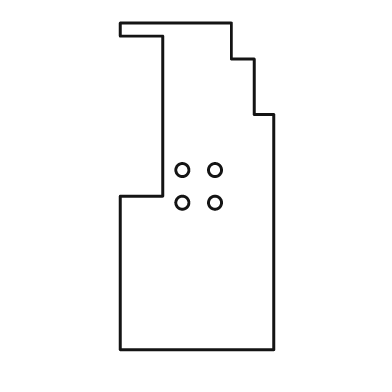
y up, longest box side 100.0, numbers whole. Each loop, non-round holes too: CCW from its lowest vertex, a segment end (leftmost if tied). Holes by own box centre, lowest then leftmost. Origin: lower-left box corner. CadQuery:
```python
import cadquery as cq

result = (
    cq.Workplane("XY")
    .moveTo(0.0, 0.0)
    .lineTo(47.0, 0.0)
    .lineTo(47.0, 72.0)
    .lineTo(41.0, 72.0)
    .lineTo(41.0, 89.0)
    .lineTo(34.0, 89.0)
    .lineTo(34.0, 100.0)
    .lineTo(0.0, 100.0)
    .lineTo(0.0, 96.0)
    .lineTo(13.0, 96.0)
    .lineTo(13.0, 47.0)
    .lineTo(0.0, 47.0)
    .close()
    .moveTo(19.0, 45.0)
    .circle(2.0)
    .moveTo(29.0, 45.0)
    .circle(2.0)
    .moveTo(19.0, 55.0)
    .circle(2.0)
    .moveTo(29.0, 55.0)
    .circle(2.0)
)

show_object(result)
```